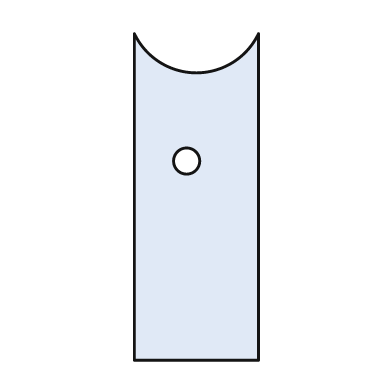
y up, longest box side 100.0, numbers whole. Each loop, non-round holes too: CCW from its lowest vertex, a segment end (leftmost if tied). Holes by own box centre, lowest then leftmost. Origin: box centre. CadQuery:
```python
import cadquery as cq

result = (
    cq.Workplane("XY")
    .moveTo(-19.0, -50.0)
    .lineTo(19.0, -50.0)
    .lineTo(19.0, 50.0)
    .threePointArc((0.0, 38.0), (-19.0, 50.0))
    .close()
    .moveTo(-3.0, 11.0)
    .circle(4.0)
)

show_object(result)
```